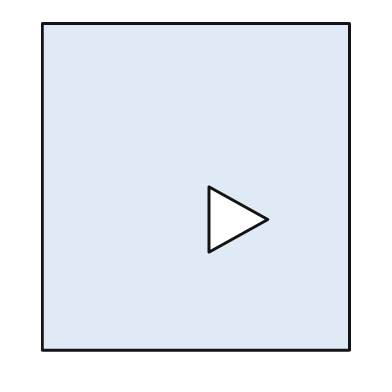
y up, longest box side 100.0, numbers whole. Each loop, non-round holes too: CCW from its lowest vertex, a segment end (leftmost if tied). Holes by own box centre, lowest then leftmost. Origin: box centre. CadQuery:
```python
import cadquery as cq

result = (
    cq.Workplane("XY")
    .moveTo(-47.0, -50.0)
    .lineTo(47.0, -50.0)
    .lineTo(47.0, 50.0)
    .lineTo(-47.0, 50.0)
    .close()
    .moveTo(4.0, -20.0)
    .lineTo(22.0, -10.0)
    .lineTo(4.0, 0.0)
    .close()
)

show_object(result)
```